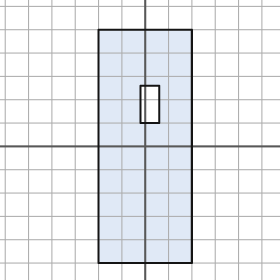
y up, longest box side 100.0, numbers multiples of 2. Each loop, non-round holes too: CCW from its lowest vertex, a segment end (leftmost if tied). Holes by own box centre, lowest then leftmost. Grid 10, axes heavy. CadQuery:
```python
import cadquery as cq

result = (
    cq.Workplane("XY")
    .moveTo(-20.0, -50.0)
    .lineTo(20.0, -50.0)
    .lineTo(20.0, 50.0)
    .lineTo(-20.0, 50.0)
    .close()
    .moveTo(-2.0, 10.0)
    .lineTo(6.0, 10.0)
    .lineTo(6.0, 26.0)
    .lineTo(-2.0, 26.0)
    .close()
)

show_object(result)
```